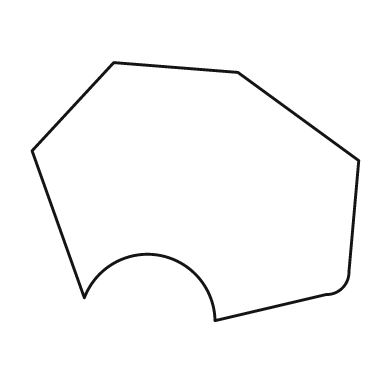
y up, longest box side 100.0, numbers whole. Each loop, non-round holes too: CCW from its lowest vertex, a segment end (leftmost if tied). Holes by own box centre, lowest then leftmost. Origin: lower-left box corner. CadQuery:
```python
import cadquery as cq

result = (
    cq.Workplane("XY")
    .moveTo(56.0, 0.0)
    .lineTo(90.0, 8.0)
    .threePointArc((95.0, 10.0), (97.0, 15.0))
    .lineTo(100.0, 49.0)
    .lineTo(63.0, 76.0)
    .lineTo(25.0, 79.0)
    .lineTo(0.0, 52.0)
    .lineTo(16.0, 7.0)
    .threePointArc((39.0, 20.0), (56.0, 0.0))
    .close()
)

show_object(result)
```